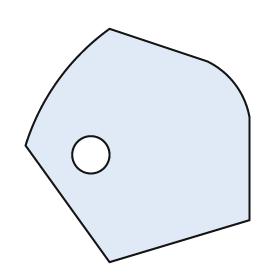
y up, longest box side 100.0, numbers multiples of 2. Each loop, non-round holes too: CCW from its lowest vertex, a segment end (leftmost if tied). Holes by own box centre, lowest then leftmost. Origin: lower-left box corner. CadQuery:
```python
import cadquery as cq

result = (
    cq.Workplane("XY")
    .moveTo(36.0, 0.0)
    .lineTo(96.0, 18.0)
    .lineTo(96.0, 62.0)
    .threePointArc((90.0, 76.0), (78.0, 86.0))
    .lineTo(36.0, 100.0)
    .threePointArc((14.0, 78.0), (0.0, 50.0))
    .close()
    .moveTo(28.0, 46.0)
    .circle(8.0)
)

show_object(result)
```